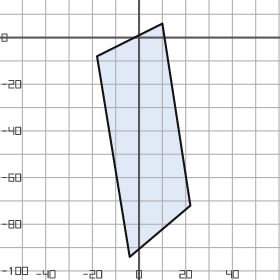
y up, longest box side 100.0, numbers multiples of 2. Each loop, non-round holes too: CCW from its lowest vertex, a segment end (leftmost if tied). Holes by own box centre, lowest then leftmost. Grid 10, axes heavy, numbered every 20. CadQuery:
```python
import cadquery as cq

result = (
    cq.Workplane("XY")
    .moveTo(-4.0, -94.0)
    .lineTo(22.0, -72.0)
    .lineTo(10.0, 6.0)
    .lineTo(-18.0, -8.0)
    .close()
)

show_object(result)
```